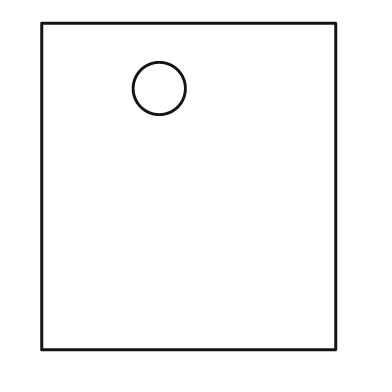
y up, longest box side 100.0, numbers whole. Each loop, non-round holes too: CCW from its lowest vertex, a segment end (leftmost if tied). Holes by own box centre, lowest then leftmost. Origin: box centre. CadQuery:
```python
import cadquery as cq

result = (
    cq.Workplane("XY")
    .moveTo(-45.0, -50.0)
    .lineTo(45.0, -50.0)
    .lineTo(45.0, 50.0)
    .lineTo(-45.0, 50.0)
    .close()
    .moveTo(-9.0, 30.0)
    .circle(8.0)
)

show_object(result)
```